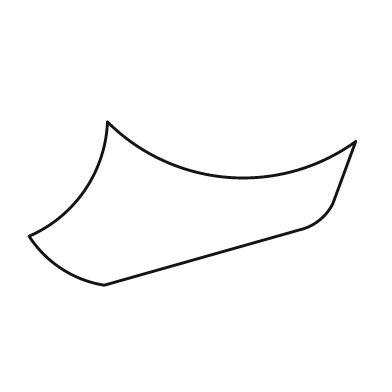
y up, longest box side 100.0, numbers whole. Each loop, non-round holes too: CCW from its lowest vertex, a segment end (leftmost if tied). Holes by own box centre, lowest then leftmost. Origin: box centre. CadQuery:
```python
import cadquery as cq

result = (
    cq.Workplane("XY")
    .moveTo(-27.0, -25.0)
    .lineTo(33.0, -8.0)
    .threePointArc((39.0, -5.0), (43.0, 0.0))
    .lineTo(50.0, 19.0)
    .threePointArc((11.0, 8.0), (-26.0, 25.0))
    .threePointArc((-33.0, 4.0), (-50.0, -10.0))
    .threePointArc((-40.0, -20.0), (-27.0, -25.0))
    .close()
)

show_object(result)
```